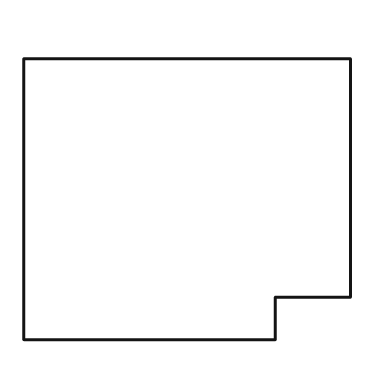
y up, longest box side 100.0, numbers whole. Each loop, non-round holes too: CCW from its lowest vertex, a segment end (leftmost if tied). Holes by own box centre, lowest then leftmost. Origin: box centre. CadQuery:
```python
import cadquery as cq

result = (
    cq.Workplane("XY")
    .moveTo(-50.0, -43.0)
    .lineTo(27.0, -43.0)
    .lineTo(27.0, -30.0)
    .lineTo(50.0, -30.0)
    .lineTo(50.0, 43.0)
    .lineTo(-50.0, 43.0)
    .close()
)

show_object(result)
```